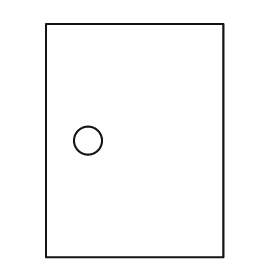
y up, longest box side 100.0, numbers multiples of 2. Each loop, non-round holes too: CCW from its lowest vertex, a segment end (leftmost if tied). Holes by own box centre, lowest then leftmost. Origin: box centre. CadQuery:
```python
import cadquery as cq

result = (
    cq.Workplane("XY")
    .moveTo(-38.0, -50.0)
    .lineTo(38.0, -50.0)
    .lineTo(38.0, 50.0)
    .lineTo(-38.0, 50.0)
    .close()
    .moveTo(-20.0, 0.0)
    .circle(6.0)
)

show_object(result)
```